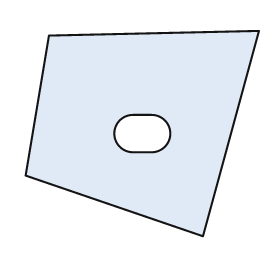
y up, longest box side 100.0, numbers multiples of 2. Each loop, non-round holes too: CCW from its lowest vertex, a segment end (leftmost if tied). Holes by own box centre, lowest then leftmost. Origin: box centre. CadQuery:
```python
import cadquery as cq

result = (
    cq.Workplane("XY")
    .moveTo(26.0, -44.0)
    .lineTo(50.0, 44.0)
    .lineTo(-40.0, 42.0)
    .lineTo(-50.0, -18.0)
    .close()
    .moveTo(-4.0, -8.0)
    .lineTo(4.0, -8.0)
    .threePointArc((12.0, 0.0), (4.0, 8.0))
    .lineTo(-4.0, 8.0)
    .threePointArc((-12.0, 0.0), (-4.0, -8.0))
    .close()
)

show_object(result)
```